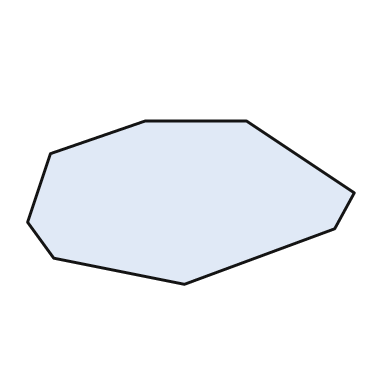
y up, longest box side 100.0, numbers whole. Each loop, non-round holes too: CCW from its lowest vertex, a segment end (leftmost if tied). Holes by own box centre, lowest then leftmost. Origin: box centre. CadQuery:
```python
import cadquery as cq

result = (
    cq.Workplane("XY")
    .moveTo(-2.0, -25.0)
    .lineTo(44.0, -8.0)
    .lineTo(50.0, 3.0)
    .lineTo(17.0, 25.0)
    .lineTo(-14.0, 25.0)
    .lineTo(-43.0, 15.0)
    .lineTo(-50.0, -6.0)
    .lineTo(-42.0, -17.0)
    .close()
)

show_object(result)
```